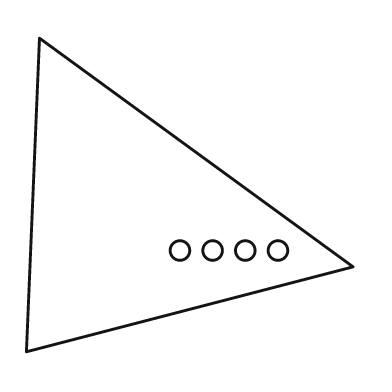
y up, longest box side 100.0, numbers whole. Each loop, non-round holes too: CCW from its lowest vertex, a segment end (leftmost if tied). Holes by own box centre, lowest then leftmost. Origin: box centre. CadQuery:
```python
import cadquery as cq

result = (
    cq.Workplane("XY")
    .moveTo(-50.0, -48.0)
    .lineTo(50.0, -22.0)
    .lineTo(-46.0, 48.0)
    .close()
    .moveTo(-3.0, -17.0)
    .circle(3.0)
    .moveTo(7.0, -17.0)
    .circle(3.0)
    .moveTo(17.0, -17.0)
    .circle(3.0)
    .moveTo(27.0, -17.0)
    .circle(3.0)
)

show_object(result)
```